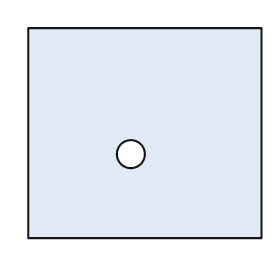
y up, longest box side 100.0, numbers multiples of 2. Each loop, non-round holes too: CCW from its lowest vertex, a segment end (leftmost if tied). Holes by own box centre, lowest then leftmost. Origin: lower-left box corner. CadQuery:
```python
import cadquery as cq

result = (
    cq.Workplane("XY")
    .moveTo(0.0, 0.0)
    .lineTo(100.0, 0.0)
    .lineTo(100.0, 90.0)
    .lineTo(0.0, 90.0)
    .close()
    .moveTo(44.0, 36.0)
    .circle(6.0)
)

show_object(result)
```